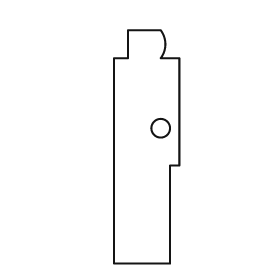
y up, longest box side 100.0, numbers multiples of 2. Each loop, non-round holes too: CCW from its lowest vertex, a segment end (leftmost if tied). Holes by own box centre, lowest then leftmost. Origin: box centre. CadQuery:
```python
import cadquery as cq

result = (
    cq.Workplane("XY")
    .moveTo(-14.0, -50.0)
    .lineTo(10.0, -50.0)
    .lineTo(10.0, -8.0)
    .lineTo(14.0, -8.0)
    .lineTo(14.0, 38.0)
    .lineTo(6.0, 38.0)
    .threePointArc((8.0, 44.0), (6.0, 50.0))
    .lineTo(-8.0, 50.0)
    .lineTo(-8.0, 38.0)
    .lineTo(-14.0, 38.0)
    .close()
    .moveTo(6.0, 8.0)
    .circle(4.0)
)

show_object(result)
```